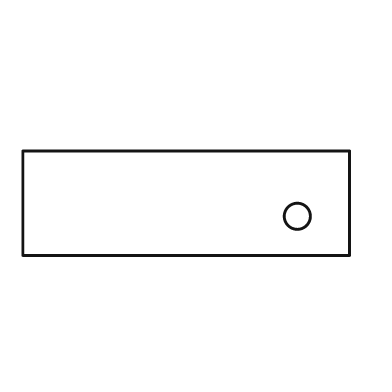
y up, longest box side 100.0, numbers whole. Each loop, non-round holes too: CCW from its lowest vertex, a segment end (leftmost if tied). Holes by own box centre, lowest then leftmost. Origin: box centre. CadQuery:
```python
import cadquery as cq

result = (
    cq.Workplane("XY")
    .moveTo(-50.0, -16.0)
    .lineTo(50.0, -16.0)
    .lineTo(50.0, 16.0)
    .lineTo(-50.0, 16.0)
    .close()
    .moveTo(34.0, -4.0)
    .circle(4.0)
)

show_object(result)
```